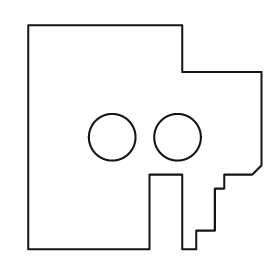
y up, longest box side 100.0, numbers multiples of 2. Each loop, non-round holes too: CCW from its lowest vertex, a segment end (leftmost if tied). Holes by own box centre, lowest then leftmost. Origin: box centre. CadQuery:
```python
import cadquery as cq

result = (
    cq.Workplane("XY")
    .moveTo(-50.0, -48.0)
    .lineTo(2.0, -48.0)
    .lineTo(2.0, -16.0)
    .lineTo(16.0, -16.0)
    .lineTo(16.0, -48.0)
    .lineTo(22.0, -48.0)
    .lineTo(22.0, -40.0)
    .lineTo(30.0, -40.0)
    .lineTo(30.0, -22.0)
    .lineTo(34.0, -22.0)
    .lineTo(34.0, -16.0)
    .lineTo(46.0, -16.0)
    .lineTo(50.0, -12.0)
    .lineTo(50.0, 28.0)
    .lineTo(16.0, 28.0)
    .lineTo(16.0, 48.0)
    .lineTo(-50.0, 48.0)
    .close()
    .moveTo(-14.0, 0.0)
    .circle(10.0)
    .moveTo(14.0, 0.0)
    .circle(10.0)
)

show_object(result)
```